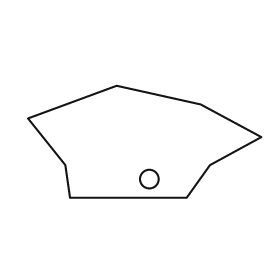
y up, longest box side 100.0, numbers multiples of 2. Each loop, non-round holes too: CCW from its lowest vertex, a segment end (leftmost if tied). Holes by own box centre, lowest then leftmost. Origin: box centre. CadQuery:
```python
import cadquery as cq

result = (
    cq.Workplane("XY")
    .moveTo(-32.0, -24.0)
    .lineTo(18.0, -24.0)
    .lineTo(28.0, -10.0)
    .lineTo(50.0, 2.0)
    .lineTo(24.0, 16.0)
    .lineTo(-12.0, 24.0)
    .lineTo(-50.0, 10.0)
    .lineTo(-34.0, -10.0)
    .close()
    .moveTo(2.0, -16.0)
    .circle(4.0)
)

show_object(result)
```